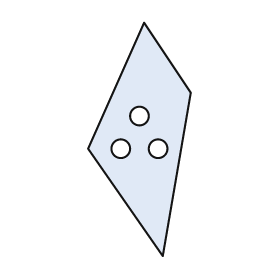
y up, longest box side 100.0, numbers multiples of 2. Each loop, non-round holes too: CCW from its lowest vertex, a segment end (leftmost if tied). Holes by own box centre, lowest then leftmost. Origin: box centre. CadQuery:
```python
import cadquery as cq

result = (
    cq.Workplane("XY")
    .moveTo(10.0, -50.0)
    .lineTo(22.0, 20.0)
    .lineTo(2.0, 50.0)
    .lineTo(-22.0, -4.0)
    .close()
    .moveTo(-8.0, -4.0)
    .circle(4.0)
    .moveTo(8.0, -4.0)
    .circle(4.0)
    .moveTo(0.0, 10.0)
    .circle(4.0)
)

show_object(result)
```